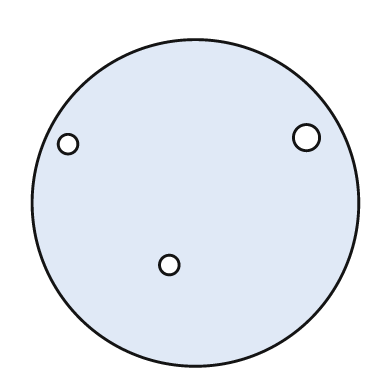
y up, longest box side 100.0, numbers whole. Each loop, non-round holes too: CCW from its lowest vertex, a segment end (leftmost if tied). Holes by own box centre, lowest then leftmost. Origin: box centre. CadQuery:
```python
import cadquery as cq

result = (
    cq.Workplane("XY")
    .moveTo(0.0, 0.0)
    .circle(50.0)
    .moveTo(-8.0, -19.0)
    .circle(3.0)
    .moveTo(-39.0, 18.0)
    .circle(3.0)
    .moveTo(34.0, 20.0)
    .circle(4.0)
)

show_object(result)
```